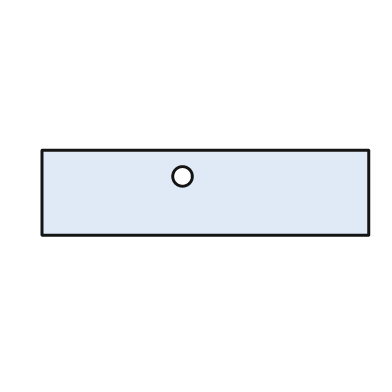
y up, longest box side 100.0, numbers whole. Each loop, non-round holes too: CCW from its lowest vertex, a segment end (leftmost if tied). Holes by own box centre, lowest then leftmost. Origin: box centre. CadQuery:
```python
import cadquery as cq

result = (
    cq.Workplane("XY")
    .moveTo(-50.0, -13.0)
    .lineTo(50.0, -13.0)
    .lineTo(50.0, 13.0)
    .lineTo(-50.0, 13.0)
    .close()
    .moveTo(-7.0, 5.0)
    .circle(3.0)
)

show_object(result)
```